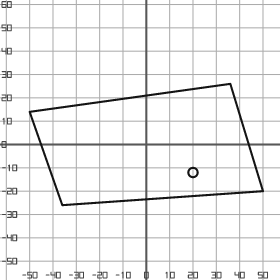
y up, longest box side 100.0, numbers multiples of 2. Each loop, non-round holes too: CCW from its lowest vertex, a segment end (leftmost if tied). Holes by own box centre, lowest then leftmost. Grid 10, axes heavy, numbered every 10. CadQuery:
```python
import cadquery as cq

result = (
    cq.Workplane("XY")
    .moveTo(-36.0, -26.0)
    .lineTo(50.0, -20.0)
    .lineTo(36.0, 26.0)
    .lineTo(-50.0, 14.0)
    .close()
    .moveTo(20.0, -12.0)
    .circle(2.0)
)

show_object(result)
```